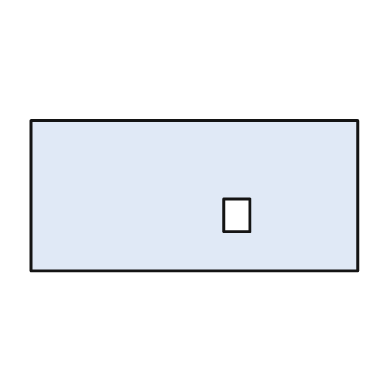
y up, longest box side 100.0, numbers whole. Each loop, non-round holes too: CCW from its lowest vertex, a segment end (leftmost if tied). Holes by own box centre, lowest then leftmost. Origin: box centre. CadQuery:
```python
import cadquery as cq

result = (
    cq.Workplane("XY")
    .moveTo(-50.0, -23.0)
    .lineTo(50.0, -23.0)
    .lineTo(50.0, 23.0)
    .lineTo(-50.0, 23.0)
    .close()
    .moveTo(9.0, -11.0)
    .lineTo(17.0, -11.0)
    .lineTo(17.0, -1.0)
    .lineTo(9.0, -1.0)
    .close()
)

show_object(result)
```